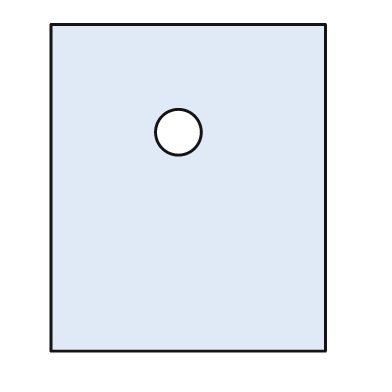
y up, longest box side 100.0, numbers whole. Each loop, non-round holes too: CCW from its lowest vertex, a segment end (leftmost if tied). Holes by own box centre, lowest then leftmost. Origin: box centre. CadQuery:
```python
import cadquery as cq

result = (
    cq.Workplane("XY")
    .moveTo(-42.0, -50.0)
    .lineTo(42.0, -50.0)
    .lineTo(42.0, 50.0)
    .lineTo(-42.0, 50.0)
    .close()
    .moveTo(-3.0, 17.0)
    .circle(7.0)
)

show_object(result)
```